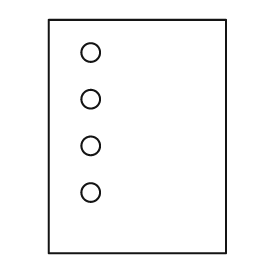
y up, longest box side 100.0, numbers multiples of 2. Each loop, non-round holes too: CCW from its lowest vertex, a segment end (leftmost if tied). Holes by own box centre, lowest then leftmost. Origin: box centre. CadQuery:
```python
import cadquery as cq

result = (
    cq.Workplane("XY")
    .moveTo(-38.0, -50.0)
    .lineTo(38.0, -50.0)
    .lineTo(38.0, 50.0)
    .lineTo(-38.0, 50.0)
    .close()
    .moveTo(-20.0, -24.0)
    .circle(4.0)
    .moveTo(-20.0, -4.0)
    .circle(4.0)
    .moveTo(-20.0, 16.0)
    .circle(4.0)
    .moveTo(-20.0, 36.0)
    .circle(4.0)
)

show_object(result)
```